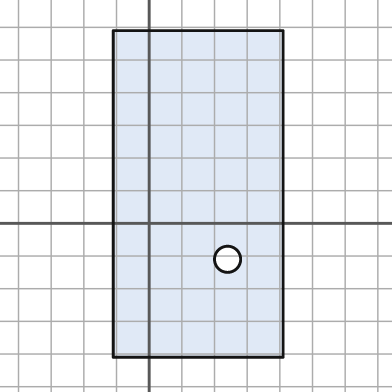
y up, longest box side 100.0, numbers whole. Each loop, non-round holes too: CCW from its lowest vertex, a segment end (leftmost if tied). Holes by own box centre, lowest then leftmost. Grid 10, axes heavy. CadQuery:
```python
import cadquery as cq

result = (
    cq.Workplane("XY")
    .moveTo(-11.0, -41.0)
    .lineTo(41.0, -41.0)
    .lineTo(41.0, 59.0)
    .lineTo(-11.0, 59.0)
    .close()
    .moveTo(24.0, -11.0)
    .circle(4.0)
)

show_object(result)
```